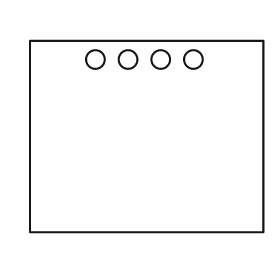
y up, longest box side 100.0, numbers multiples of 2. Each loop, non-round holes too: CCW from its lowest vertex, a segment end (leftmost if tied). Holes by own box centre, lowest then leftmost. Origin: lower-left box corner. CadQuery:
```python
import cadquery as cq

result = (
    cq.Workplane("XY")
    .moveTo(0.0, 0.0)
    .lineTo(100.0, 0.0)
    .lineTo(100.0, 82.0)
    .lineTo(0.0, 82.0)
    .close()
    .moveTo(28.0, 74.0)
    .circle(4.0)
    .moveTo(42.0, 74.0)
    .circle(4.0)
    .moveTo(56.0, 74.0)
    .circle(4.0)
    .moveTo(70.0, 74.0)
    .circle(4.0)
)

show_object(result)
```